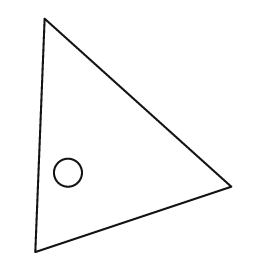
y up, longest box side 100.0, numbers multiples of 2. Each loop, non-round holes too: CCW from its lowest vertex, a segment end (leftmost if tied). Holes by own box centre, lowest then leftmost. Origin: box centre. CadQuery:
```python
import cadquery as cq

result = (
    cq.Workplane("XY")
    .moveTo(-42.0, -50.0)
    .lineTo(42.0, -22.0)
    .lineTo(-38.0, 50.0)
    .close()
    .moveTo(-28.0, -16.0)
    .circle(6.0)
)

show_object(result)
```